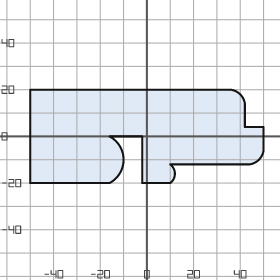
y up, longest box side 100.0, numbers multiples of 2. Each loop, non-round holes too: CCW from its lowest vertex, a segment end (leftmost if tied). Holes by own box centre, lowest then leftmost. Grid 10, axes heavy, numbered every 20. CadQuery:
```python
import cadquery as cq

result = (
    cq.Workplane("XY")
    .moveTo(-50.0, -20.0)
    .lineTo(-16.0, -20.0)
    .threePointArc((-10.0, -10.0), (-16.0, 0.0))
    .lineTo(-2.0, 0.0)
    .lineTo(-2.0, -20.0)
    .lineTo(10.0, -20.0)
    .threePointArc((12.0, -16.0), (10.0, -12.0))
    .lineTo(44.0, -12.0)
    .threePointArc((48.0, -10.0), (50.0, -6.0))
    .lineTo(50.0, 4.0)
    .lineTo(42.0, 4.0)
    .lineTo(42.0, 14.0)
    .threePointArc((40.0, 18.0), (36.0, 20.0))
    .lineTo(-50.0, 20.0)
    .close()
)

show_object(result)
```